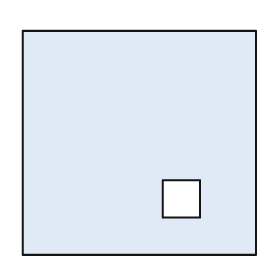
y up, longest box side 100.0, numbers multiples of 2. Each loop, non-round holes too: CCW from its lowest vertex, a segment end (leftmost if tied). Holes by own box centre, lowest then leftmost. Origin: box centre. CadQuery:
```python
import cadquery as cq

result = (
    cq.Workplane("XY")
    .moveTo(-50.0, -48.0)
    .lineTo(50.0, -48.0)
    .lineTo(50.0, 48.0)
    .lineTo(-50.0, 48.0)
    .close()
    .moveTo(10.0, -32.0)
    .lineTo(26.0, -32.0)
    .lineTo(26.0, -16.0)
    .lineTo(10.0, -16.0)
    .close()
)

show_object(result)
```